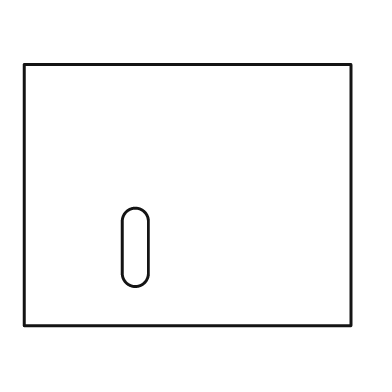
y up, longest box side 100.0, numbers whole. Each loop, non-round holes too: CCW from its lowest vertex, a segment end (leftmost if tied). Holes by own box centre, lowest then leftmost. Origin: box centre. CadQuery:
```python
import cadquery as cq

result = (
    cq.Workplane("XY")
    .moveTo(-50.0, -40.0)
    .lineTo(50.0, -40.0)
    .lineTo(50.0, 40.0)
    .lineTo(-50.0, 40.0)
    .close()
    .moveTo(-20.0, -24.0)
    .threePointArc((-16.0, -28.0), (-12.0, -24.0))
    .lineTo(-12.0, -8.0)
    .threePointArc((-16.0, -4.0), (-20.0, -8.0))
    .close()
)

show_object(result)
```